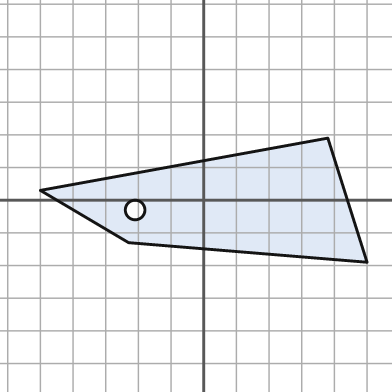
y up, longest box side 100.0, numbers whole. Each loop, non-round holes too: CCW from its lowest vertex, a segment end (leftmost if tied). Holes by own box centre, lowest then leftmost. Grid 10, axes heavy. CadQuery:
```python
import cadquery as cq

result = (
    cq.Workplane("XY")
    .moveTo(50.0, -19.0)
    .lineTo(38.0, 19.0)
    .lineTo(-50.0, 3.0)
    .lineTo(-23.0, -13.0)
    .close()
    .moveTo(-21.0, -3.0)
    .circle(3.0)
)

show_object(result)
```